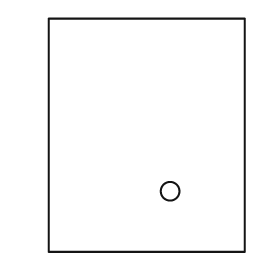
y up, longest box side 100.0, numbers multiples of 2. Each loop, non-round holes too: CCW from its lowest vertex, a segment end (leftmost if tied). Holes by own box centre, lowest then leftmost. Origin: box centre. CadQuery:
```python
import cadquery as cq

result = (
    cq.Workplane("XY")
    .moveTo(-42.0, -50.0)
    .lineTo(42.0, -50.0)
    .lineTo(42.0, 50.0)
    .lineTo(-42.0, 50.0)
    .close()
    .moveTo(10.0, -24.0)
    .circle(4.0)
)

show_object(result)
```